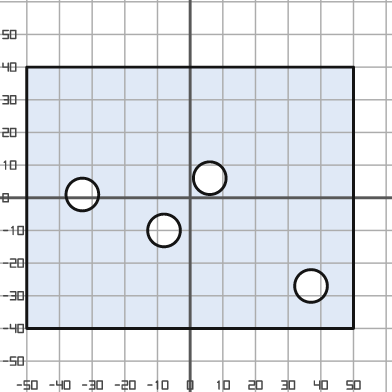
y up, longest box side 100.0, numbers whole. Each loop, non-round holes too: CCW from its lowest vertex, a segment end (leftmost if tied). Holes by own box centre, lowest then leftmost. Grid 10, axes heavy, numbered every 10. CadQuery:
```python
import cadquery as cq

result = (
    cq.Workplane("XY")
    .moveTo(-50.0, -40.0)
    .lineTo(50.0, -40.0)
    .lineTo(50.0, 40.0)
    .lineTo(-50.0, 40.0)
    .close()
    .moveTo(37.0, -27.0)
    .circle(5.0)
    .moveTo(-8.0, -10.0)
    .circle(5.0)
    .moveTo(-33.0, 1.0)
    .circle(5.0)
    .moveTo(6.0, 6.0)
    .circle(5.0)
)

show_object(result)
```